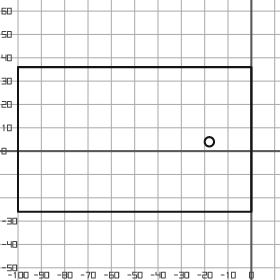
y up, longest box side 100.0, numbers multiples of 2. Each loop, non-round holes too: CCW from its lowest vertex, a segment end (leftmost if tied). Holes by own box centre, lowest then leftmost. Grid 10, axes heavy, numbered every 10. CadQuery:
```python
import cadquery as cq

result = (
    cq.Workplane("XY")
    .moveTo(-100.0, -26.0)
    .lineTo(0.0, -26.0)
    .lineTo(0.0, 36.0)
    .lineTo(-100.0, 36.0)
    .close()
    .moveTo(-18.0, 4.0)
    .circle(2.0)
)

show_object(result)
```